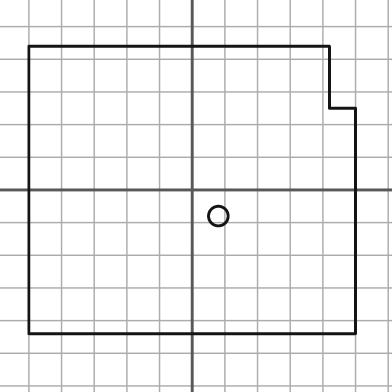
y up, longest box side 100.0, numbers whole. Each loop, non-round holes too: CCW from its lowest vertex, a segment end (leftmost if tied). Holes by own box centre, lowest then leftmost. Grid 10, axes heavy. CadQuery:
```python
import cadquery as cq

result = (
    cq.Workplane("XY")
    .moveTo(-50.0, -44.0)
    .lineTo(50.0, -44.0)
    .lineTo(50.0, 25.0)
    .lineTo(42.0, 25.0)
    .lineTo(42.0, 44.0)
    .lineTo(-50.0, 44.0)
    .close()
    .moveTo(8.0, -8.0)
    .circle(3.0)
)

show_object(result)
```